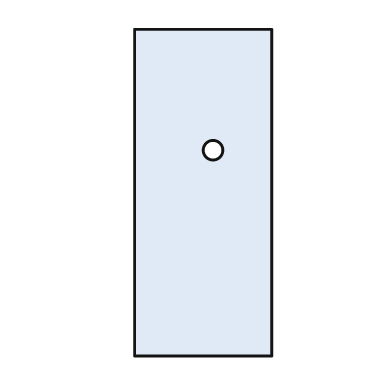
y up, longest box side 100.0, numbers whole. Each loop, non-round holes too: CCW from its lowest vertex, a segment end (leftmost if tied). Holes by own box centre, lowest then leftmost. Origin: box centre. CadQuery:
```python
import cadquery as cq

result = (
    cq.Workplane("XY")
    .moveTo(-21.0, -50.0)
    .lineTo(21.0, -50.0)
    .lineTo(21.0, 50.0)
    .lineTo(-21.0, 50.0)
    .close()
    .moveTo(3.0, 13.0)
    .circle(3.0)
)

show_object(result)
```